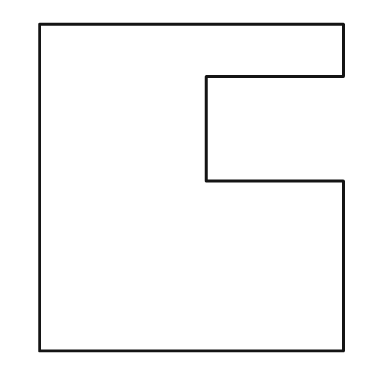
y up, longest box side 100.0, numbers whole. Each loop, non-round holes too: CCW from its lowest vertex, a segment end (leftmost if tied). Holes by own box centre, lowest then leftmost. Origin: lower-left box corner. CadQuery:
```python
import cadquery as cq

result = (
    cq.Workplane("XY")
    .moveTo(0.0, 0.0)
    .lineTo(93.0, 0.0)
    .lineTo(93.0, 52.0)
    .lineTo(51.0, 52.0)
    .lineTo(51.0, 84.0)
    .lineTo(93.0, 84.0)
    .lineTo(93.0, 100.0)
    .lineTo(0.0, 100.0)
    .close()
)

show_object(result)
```